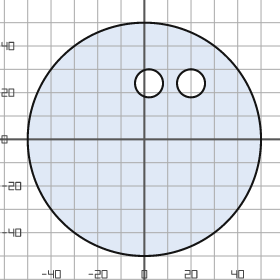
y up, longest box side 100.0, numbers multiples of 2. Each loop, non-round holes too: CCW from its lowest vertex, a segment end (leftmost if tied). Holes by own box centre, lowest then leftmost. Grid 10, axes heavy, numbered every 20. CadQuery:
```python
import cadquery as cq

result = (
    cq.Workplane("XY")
    .moveTo(0.0, 0.0)
    .circle(50.0)
    .moveTo(2.0, 24.0)
    .circle(6.0)
    .moveTo(20.0, 24.0)
    .circle(6.0)
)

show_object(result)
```